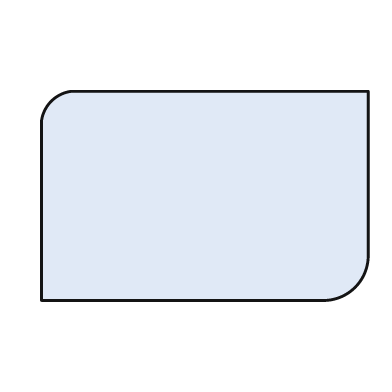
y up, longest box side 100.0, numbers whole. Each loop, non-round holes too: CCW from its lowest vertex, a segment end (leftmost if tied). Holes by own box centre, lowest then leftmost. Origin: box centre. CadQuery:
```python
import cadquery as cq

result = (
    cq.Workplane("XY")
    .moveTo(-50.0, -32.0)
    .lineTo(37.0, -32.0)
    .threePointArc((46.0, -28.0), (50.0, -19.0))
    .lineTo(50.0, 32.0)
    .lineTo(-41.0, 32.0)
    .threePointArc((-47.0, 29.0), (-50.0, 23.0))
    .close()
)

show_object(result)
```